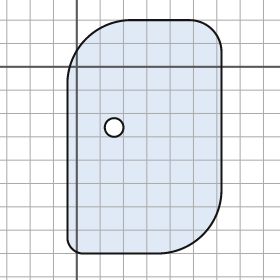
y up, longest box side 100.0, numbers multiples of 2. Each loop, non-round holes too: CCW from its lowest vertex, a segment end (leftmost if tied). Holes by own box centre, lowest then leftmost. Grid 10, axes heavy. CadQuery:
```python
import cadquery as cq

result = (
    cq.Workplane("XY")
    .moveTo(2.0, -80.0)
    .lineTo(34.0, -80.0)
    .threePointArc((54.0, -72.0), (62.0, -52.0))
    .lineTo(62.0, 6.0)
    .threePointArc((58.0, 16.0), (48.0, 20.0))
    .lineTo(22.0, 20.0)
    .threePointArc((4.0, 12.0), (-4.0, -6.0))
    .lineTo(-4.0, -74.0)
    .threePointArc((-2.0, -78.0), (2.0, -80.0))
    .close()
    .moveTo(16.0, -26.0)
    .circle(4.0)
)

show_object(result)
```